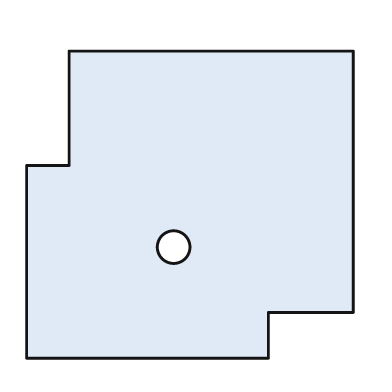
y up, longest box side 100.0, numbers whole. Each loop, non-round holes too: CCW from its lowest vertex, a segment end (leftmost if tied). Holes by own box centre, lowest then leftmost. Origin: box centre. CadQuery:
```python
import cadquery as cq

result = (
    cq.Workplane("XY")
    .moveTo(-50.0, -47.0)
    .lineTo(24.0, -47.0)
    .lineTo(24.0, -33.0)
    .lineTo(50.0, -33.0)
    .lineTo(50.0, 47.0)
    .lineTo(-37.0, 47.0)
    .lineTo(-37.0, 12.0)
    .lineTo(-50.0, 12.0)
    .close()
    .moveTo(-5.0, -13.0)
    .circle(5.0)
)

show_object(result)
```